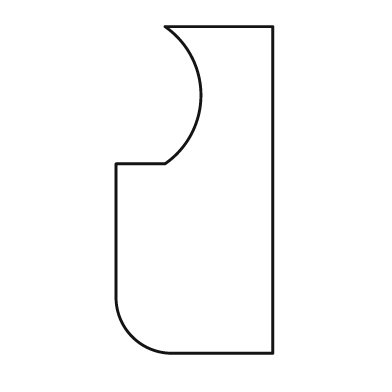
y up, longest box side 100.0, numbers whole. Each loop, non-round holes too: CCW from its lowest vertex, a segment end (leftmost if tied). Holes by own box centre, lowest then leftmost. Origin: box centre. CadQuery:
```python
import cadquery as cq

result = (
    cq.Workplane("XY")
    .moveTo(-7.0, -50.0)
    .lineTo(24.0, -50.0)
    .lineTo(24.0, 50.0)
    .lineTo(-9.0, 50.0)
    .threePointArc((2.0, 29.0), (-9.0, 8.0))
    .lineTo(-24.0, 8.0)
    .lineTo(-24.0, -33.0)
    .threePointArc((-19.0, -45.0), (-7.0, -50.0))
    .close()
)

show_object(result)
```